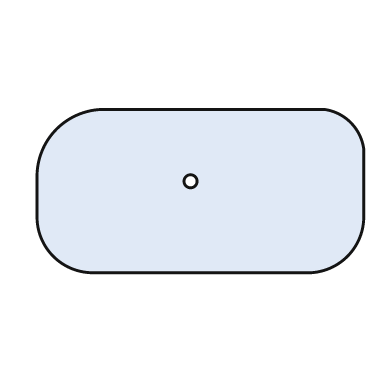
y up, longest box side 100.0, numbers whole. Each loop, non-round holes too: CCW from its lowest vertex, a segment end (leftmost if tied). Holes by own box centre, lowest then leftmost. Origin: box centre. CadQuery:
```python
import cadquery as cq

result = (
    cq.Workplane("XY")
    .moveTo(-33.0, -25.0)
    .lineTo(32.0, -25.0)
    .threePointArc((45.0, -20.0), (50.0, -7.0))
    .lineTo(50.0, 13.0)
    .threePointArc((46.0, 21.0), (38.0, 25.0))
    .lineTo(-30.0, 25.0)
    .threePointArc((-44.0, 19.0), (-50.0, 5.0))
    .lineTo(-50.0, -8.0)
    .threePointArc((-45.0, -20.0), (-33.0, -25.0))
    .close()
    .moveTo(-3.0, 3.0)
    .circle(2.0)
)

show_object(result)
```